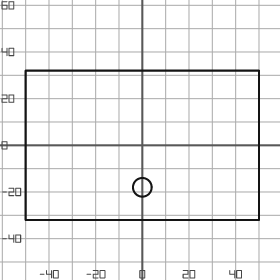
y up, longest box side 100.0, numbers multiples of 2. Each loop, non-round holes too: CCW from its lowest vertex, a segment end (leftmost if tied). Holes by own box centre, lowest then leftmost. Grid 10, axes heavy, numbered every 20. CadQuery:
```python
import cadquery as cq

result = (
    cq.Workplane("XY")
    .moveTo(-50.0, -32.0)
    .lineTo(50.0, -32.0)
    .lineTo(50.0, 32.0)
    .lineTo(-50.0, 32.0)
    .close()
    .moveTo(0.0, -18.0)
    .circle(4.0)
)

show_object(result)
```